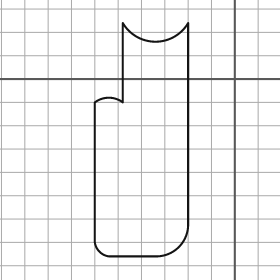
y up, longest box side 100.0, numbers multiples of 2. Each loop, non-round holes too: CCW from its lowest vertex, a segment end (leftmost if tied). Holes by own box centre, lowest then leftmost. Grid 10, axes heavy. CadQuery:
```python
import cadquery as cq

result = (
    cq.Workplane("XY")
    .moveTo(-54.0, -76.0)
    .lineTo(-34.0, -76.0)
    .threePointArc((-24.0, -72.0), (-20.0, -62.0))
    .lineTo(-20.0, 24.0)
    .threePointArc((-34.0, 16.0), (-48.0, 24.0))
    .lineTo(-48.0, -10.0)
    .threePointArc((-54.0, -8.0), (-60.0, -10.0))
    .lineTo(-60.0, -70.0)
    .threePointArc((-58.0, -74.0), (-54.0, -76.0))
    .close()
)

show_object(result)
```